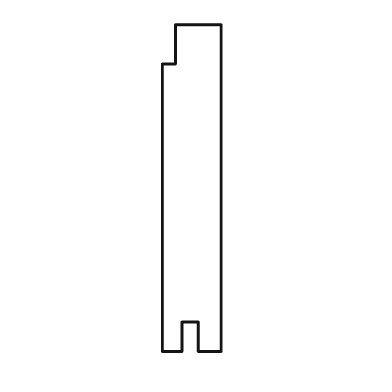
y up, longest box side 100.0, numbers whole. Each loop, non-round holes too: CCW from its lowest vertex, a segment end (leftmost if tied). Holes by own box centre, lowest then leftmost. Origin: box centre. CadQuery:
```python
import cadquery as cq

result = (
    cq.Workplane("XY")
    .moveTo(-9.0, -50.0)
    .lineTo(-3.0, -50.0)
    .lineTo(-3.0, -41.0)
    .lineTo(2.0, -41.0)
    .lineTo(2.0, -50.0)
    .lineTo(9.0, -50.0)
    .lineTo(9.0, 50.0)
    .lineTo(-5.0, 50.0)
    .lineTo(-5.0, 38.0)
    .lineTo(-9.0, 38.0)
    .close()
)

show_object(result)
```